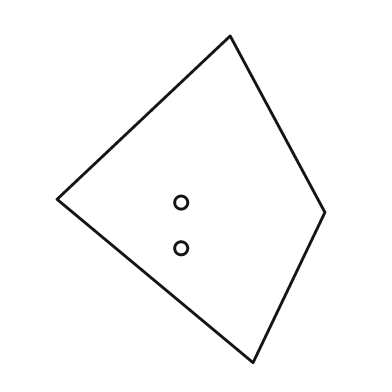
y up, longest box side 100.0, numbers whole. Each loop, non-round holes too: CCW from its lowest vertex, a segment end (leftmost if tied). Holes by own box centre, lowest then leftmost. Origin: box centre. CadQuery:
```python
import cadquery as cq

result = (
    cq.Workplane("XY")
    .moveTo(19.0, -50.0)
    .lineTo(41.0, -4.0)
    .lineTo(12.0, 50.0)
    .lineTo(-41.0, 0.0)
    .close()
    .moveTo(-3.0, -15.0)
    .circle(2.0)
    .moveTo(-3.0, -1.0)
    .circle(2.0)
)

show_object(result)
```